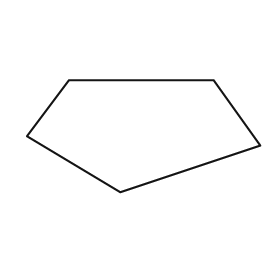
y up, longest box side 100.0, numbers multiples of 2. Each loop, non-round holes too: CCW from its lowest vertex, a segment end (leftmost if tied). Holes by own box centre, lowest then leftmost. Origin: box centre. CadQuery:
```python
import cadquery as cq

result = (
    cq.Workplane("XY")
    .moveTo(-10.0, -24.0)
    .lineTo(50.0, -4.0)
    .lineTo(30.0, 24.0)
    .lineTo(-32.0, 24.0)
    .lineTo(-50.0, 0.0)
    .close()
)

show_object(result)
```